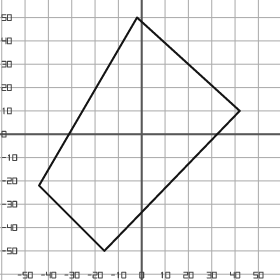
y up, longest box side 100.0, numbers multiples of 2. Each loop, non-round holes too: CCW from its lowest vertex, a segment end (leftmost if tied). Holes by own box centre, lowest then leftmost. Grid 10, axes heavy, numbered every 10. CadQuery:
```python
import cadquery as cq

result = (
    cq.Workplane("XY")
    .moveTo(-16.0, -50.0)
    .lineTo(42.0, 10.0)
    .lineTo(-2.0, 50.0)
    .lineTo(-44.0, -22.0)
    .close()
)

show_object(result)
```